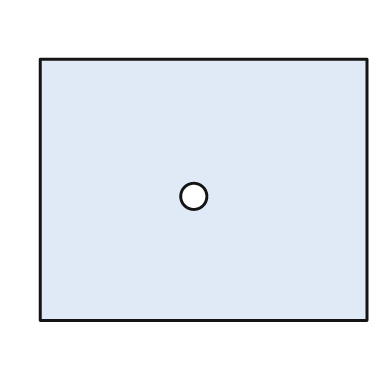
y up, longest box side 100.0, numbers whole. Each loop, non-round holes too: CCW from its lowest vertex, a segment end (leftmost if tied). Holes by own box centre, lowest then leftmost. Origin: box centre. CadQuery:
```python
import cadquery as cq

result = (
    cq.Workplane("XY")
    .moveTo(-50.0, -40.0)
    .lineTo(50.0, -40.0)
    .lineTo(50.0, 40.0)
    .lineTo(-50.0, 40.0)
    .close()
    .moveTo(-3.0, -2.0)
    .circle(4.0)
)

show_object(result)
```